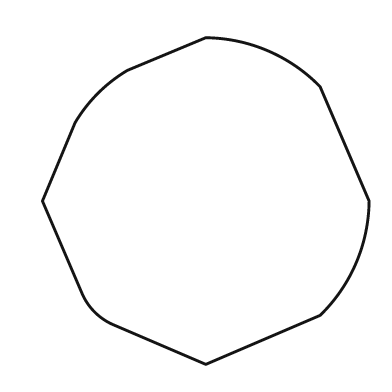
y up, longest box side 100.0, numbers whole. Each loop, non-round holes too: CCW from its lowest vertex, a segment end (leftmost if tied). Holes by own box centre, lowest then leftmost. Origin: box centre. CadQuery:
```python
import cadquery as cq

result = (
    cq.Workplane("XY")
    .moveTo(0.0, -50.0)
    .lineTo(35.0, -35.0)
    .threePointArc((46.0, -19.0), (50.0, 0.0))
    .lineTo(35.0, 35.0)
    .threePointArc((19.0, 46.0), (0.0, 50.0))
    .lineTo(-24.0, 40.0)
    .threePointArc((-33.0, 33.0), (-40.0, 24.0))
    .lineTo(-50.0, 0.0)
    .lineTo(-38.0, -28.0)
    .threePointArc((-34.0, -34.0), (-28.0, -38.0))
    .close()
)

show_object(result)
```